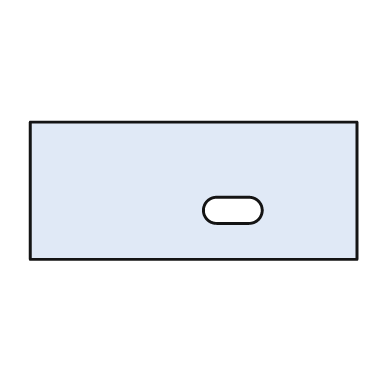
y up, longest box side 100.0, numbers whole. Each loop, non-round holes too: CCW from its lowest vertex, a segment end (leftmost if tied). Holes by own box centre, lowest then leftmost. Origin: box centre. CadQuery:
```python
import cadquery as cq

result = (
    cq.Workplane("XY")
    .moveTo(-50.0, -21.0)
    .lineTo(50.0, -21.0)
    .lineTo(50.0, 21.0)
    .lineTo(-50.0, 21.0)
    .close()
    .moveTo(7.0, -10.0)
    .lineTo(17.0, -10.0)
    .threePointArc((21.0, -6.0), (17.0, -2.0))
    .lineTo(7.0, -2.0)
    .threePointArc((3.0, -6.0), (7.0, -10.0))
    .close()
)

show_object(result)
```